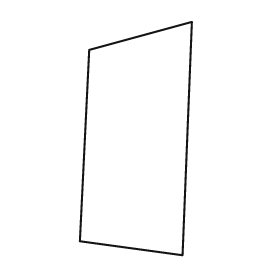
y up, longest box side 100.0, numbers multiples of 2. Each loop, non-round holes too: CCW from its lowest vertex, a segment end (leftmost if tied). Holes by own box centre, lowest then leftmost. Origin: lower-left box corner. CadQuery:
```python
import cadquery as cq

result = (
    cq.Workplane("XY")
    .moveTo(44.0, 0.0)
    .lineTo(48.0, 100.0)
    .lineTo(4.0, 88.0)
    .lineTo(0.0, 6.0)
    .close()
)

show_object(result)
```